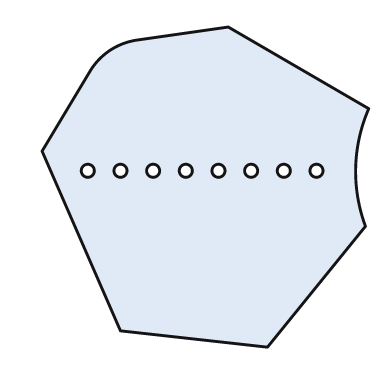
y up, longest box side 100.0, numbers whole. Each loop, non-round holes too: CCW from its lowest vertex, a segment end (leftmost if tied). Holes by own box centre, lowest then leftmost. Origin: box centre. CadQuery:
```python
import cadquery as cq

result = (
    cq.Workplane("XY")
    .moveTo(19.0, -49.0)
    .lineTo(49.0, -12.0)
    .threePointArc((46.0, 6.0), (50.0, 24.0))
    .lineTo(7.0, 49.0)
    .lineTo(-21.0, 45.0)
    .threePointArc((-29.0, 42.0), (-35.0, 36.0))
    .lineTo(-50.0, 11.0)
    .lineTo(-26.0, -44.0)
    .close()
    .moveTo(-36.0, 5.0)
    .circle(2.0)
    .moveTo(-26.0, 5.0)
    .circle(2.0)
    .moveTo(-16.0, 5.0)
    .circle(2.0)
    .moveTo(-6.0, 5.0)
    .circle(2.0)
    .moveTo(4.0, 5.0)
    .circle(2.0)
    .moveTo(14.0, 5.0)
    .circle(2.0)
    .moveTo(24.0, 5.0)
    .circle(2.0)
    .moveTo(34.0, 5.0)
    .circle(2.0)
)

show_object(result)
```